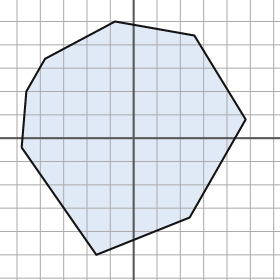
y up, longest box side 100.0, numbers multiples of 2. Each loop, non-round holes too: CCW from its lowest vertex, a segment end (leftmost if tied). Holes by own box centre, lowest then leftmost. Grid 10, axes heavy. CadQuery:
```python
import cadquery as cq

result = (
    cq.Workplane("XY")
    .moveTo(-16.0, -50.0)
    .lineTo(24.0, -34.0)
    .lineTo(48.0, 8.0)
    .lineTo(26.0, 44.0)
    .lineTo(-8.0, 50.0)
    .lineTo(-38.0, 34.0)
    .lineTo(-46.0, 20.0)
    .lineTo(-48.0, -4.0)
    .close()
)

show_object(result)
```